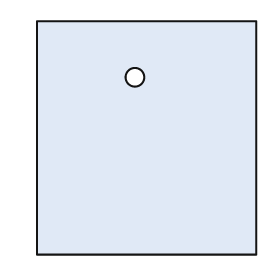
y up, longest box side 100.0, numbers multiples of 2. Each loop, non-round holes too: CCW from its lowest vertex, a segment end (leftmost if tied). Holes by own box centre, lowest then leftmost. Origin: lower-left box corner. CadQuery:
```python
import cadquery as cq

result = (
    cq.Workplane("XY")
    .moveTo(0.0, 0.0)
    .lineTo(94.0, 0.0)
    .lineTo(94.0, 100.0)
    .lineTo(0.0, 100.0)
    .close()
    .moveTo(42.0, 76.0)
    .circle(4.0)
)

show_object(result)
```